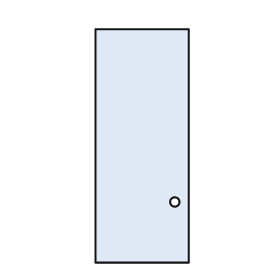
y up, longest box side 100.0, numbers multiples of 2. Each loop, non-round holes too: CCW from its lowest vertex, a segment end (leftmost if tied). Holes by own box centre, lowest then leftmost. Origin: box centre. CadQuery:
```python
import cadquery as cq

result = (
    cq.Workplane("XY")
    .moveTo(-20.0, -50.0)
    .lineTo(20.0, -50.0)
    .lineTo(20.0, 50.0)
    .lineTo(-20.0, 50.0)
    .close()
    .moveTo(14.0, -24.0)
    .circle(2.0)
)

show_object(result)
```